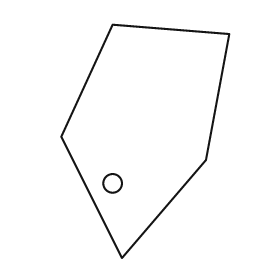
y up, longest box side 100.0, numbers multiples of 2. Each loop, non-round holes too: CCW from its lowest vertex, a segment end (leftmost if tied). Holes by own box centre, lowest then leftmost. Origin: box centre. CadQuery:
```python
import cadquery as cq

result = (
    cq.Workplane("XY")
    .moveTo(-10.0, -50.0)
    .lineTo(26.0, -8.0)
    .lineTo(36.0, 46.0)
    .lineTo(-14.0, 50.0)
    .lineTo(-36.0, 2.0)
    .close()
    .moveTo(-14.0, -18.0)
    .circle(4.0)
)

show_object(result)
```